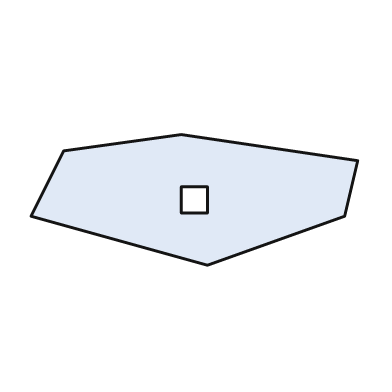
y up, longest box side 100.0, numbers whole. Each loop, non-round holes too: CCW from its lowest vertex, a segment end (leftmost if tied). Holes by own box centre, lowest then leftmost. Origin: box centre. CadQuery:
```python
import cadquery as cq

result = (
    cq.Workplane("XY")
    .moveTo(4.0, -20.0)
    .lineTo(46.0, -5.0)
    .lineTo(50.0, 12.0)
    .lineTo(-4.0, 20.0)
    .lineTo(-40.0, 15.0)
    .lineTo(-50.0, -5.0)
    .close()
    .moveTo(-4.0, -4.0)
    .lineTo(4.0, -4.0)
    .lineTo(4.0, 4.0)
    .lineTo(-4.0, 4.0)
    .close()
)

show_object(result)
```